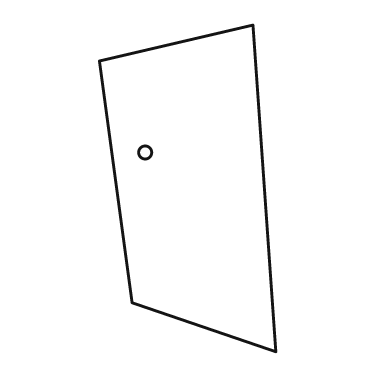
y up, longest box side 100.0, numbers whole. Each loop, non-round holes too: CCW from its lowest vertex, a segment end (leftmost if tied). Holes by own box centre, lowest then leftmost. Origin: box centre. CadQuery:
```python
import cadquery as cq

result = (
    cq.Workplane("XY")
    .moveTo(27.0, -50.0)
    .lineTo(20.0, 50.0)
    .lineTo(-27.0, 39.0)
    .lineTo(-17.0, -35.0)
    .close()
    .moveTo(-13.0, 11.0)
    .circle(2.0)
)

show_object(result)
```